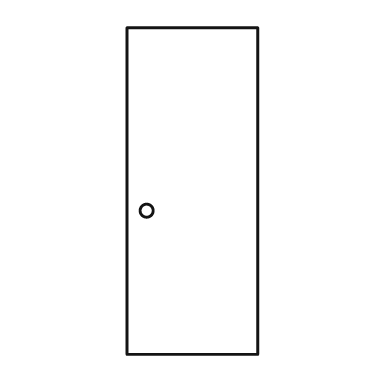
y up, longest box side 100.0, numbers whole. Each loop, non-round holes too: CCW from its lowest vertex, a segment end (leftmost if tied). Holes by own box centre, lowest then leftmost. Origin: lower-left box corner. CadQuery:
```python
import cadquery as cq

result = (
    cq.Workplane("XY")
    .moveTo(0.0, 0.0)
    .lineTo(40.0, 0.0)
    .lineTo(40.0, 100.0)
    .lineTo(0.0, 100.0)
    .close()
    .moveTo(6.0, 44.0)
    .circle(2.0)
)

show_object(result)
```